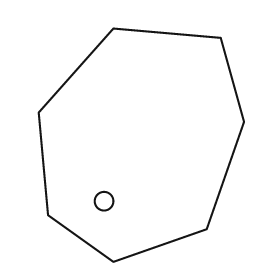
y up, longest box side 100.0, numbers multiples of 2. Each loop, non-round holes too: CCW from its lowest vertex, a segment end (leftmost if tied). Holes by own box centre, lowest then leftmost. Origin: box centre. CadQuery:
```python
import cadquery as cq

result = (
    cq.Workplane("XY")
    .moveTo(-12.0, -50.0)
    .lineTo(28.0, -36.0)
    .lineTo(44.0, 10.0)
    .lineTo(34.0, 46.0)
    .lineTo(-12.0, 50.0)
    .lineTo(-44.0, 14.0)
    .lineTo(-40.0, -30.0)
    .close()
    .moveTo(-16.0, -24.0)
    .circle(4.0)
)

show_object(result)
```